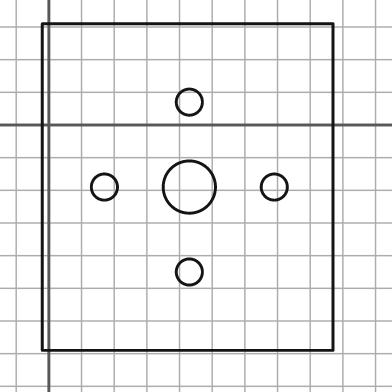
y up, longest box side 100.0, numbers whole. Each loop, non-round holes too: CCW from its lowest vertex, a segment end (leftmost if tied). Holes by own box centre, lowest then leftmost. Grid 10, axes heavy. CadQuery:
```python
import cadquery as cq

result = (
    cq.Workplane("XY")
    .moveTo(-2.0, -69.0)
    .lineTo(87.0, -69.0)
    .lineTo(87.0, 31.0)
    .lineTo(-2.0, 31.0)
    .close()
    .moveTo(43.0, -45.0)
    .circle(4.0)
    .moveTo(17.0, -19.0)
    .circle(4.0)
    .moveTo(43.0, -19.0)
    .circle(8.0)
    .moveTo(69.0, -19.0)
    .circle(4.0)
    .moveTo(43.0, 7.0)
    .circle(4.0)
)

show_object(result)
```